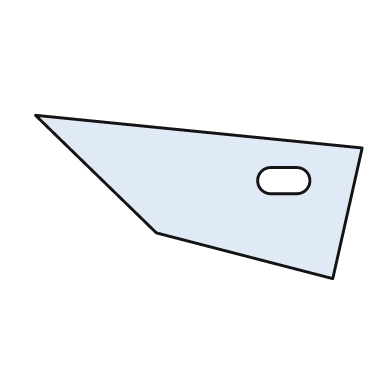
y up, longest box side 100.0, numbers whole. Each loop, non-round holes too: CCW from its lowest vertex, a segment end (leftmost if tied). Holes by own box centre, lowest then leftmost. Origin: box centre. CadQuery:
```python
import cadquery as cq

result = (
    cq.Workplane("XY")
    .moveTo(41.0, -25.0)
    .lineTo(50.0, 15.0)
    .lineTo(-50.0, 25.0)
    .lineTo(-13.0, -11.0)
    .close()
    .moveTo(22.0, 1.0)
    .lineTo(30.0, 1.0)
    .threePointArc((34.0, 5.0), (30.0, 9.0))
    .lineTo(22.0, 9.0)
    .threePointArc((18.0, 5.0), (22.0, 1.0))
    .close()
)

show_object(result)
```